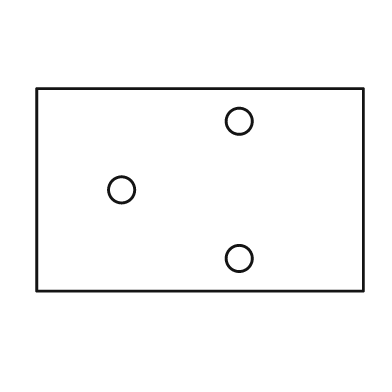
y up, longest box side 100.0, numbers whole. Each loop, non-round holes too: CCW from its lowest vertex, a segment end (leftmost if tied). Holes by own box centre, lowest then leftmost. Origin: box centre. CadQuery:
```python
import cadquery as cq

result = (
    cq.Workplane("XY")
    .moveTo(-50.0, -31.0)
    .lineTo(50.0, -31.0)
    .lineTo(50.0, 31.0)
    .lineTo(-50.0, 31.0)
    .close()
    .moveTo(12.0, -21.0)
    .circle(4.0)
    .moveTo(-24.0, 0.0)
    .circle(4.0)
    .moveTo(12.0, 21.0)
    .circle(4.0)
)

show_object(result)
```